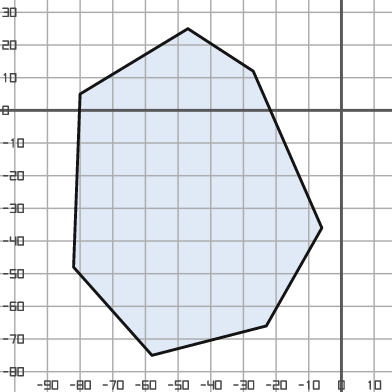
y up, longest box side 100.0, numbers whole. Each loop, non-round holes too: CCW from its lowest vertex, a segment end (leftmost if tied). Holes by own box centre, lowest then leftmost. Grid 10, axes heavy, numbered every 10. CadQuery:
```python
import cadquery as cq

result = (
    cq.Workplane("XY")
    .moveTo(-58.0, -75.0)
    .lineTo(-23.0, -66.0)
    .lineTo(-6.0, -36.0)
    .lineTo(-27.0, 12.0)
    .lineTo(-47.0, 25.0)
    .lineTo(-80.0, 5.0)
    .lineTo(-82.0, -48.0)
    .close()
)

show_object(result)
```